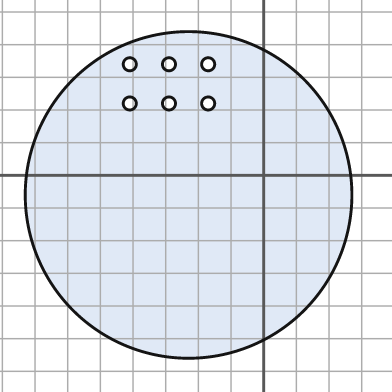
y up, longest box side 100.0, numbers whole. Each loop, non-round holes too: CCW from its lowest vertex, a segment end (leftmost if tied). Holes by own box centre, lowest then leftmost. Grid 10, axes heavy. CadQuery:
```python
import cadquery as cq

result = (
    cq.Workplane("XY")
    .moveTo(-23.0, -6.0)
    .circle(50.0)
    .moveTo(-41.0, 22.0)
    .circle(2.0)
    .moveTo(-29.0, 22.0)
    .circle(2.0)
    .moveTo(-17.0, 22.0)
    .circle(2.0)
    .moveTo(-41.0, 34.0)
    .circle(2.0)
    .moveTo(-29.0, 34.0)
    .circle(2.0)
    .moveTo(-17.0, 34.0)
    .circle(2.0)
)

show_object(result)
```